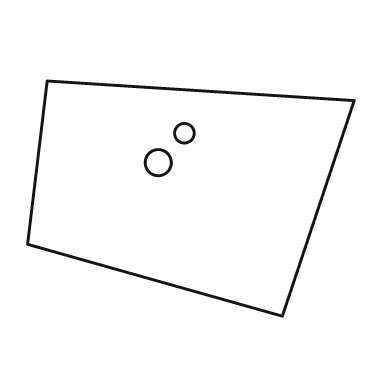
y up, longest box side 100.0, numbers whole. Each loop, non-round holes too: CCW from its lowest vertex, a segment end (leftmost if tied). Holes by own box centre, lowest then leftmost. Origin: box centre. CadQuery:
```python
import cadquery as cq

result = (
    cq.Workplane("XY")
    .moveTo(28.0, -36.0)
    .lineTo(50.0, 30.0)
    .lineTo(-44.0, 36.0)
    .lineTo(-50.0, -14.0)
    .close()
    .moveTo(-10.0, 11.0)
    .circle(4.0)
    .moveTo(-2.0, 20.0)
    .circle(3.0)
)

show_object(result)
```